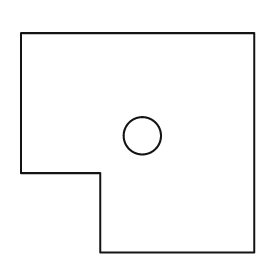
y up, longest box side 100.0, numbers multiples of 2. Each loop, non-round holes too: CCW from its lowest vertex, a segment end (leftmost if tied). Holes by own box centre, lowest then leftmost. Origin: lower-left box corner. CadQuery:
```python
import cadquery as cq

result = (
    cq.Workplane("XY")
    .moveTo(34.0, 0.0)
    .lineTo(100.0, 0.0)
    .lineTo(100.0, 94.0)
    .lineTo(0.0, 94.0)
    .lineTo(0.0, 34.0)
    .lineTo(34.0, 34.0)
    .close()
    .moveTo(52.0, 50.0)
    .circle(8.0)
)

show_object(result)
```